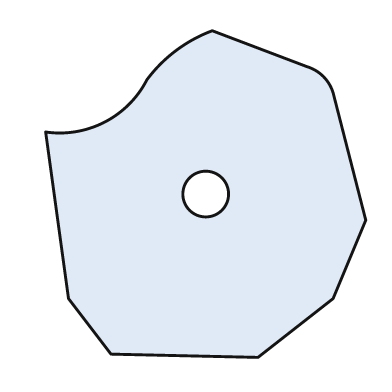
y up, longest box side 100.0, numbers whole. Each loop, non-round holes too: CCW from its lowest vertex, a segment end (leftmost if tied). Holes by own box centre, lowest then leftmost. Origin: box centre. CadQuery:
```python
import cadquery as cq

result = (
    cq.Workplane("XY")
    .moveTo(16.0, -50.0)
    .lineTo(39.0, -32.0)
    .lineTo(49.0, -8.0)
    .lineTo(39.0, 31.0)
    .threePointArc((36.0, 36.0), (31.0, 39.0))
    .lineTo(2.0, 50.0)
    .threePointArc((-9.0, 44.0), (-18.0, 35.0))
    .threePointArc((-31.0, 22.0), (-49.0, 19.0))
    .lineTo(-42.0, -32.0)
    .lineTo(-29.0, -49.0)
    .close()
    .moveTo(0.0, 0.0)
    .circle(7.0)
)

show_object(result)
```